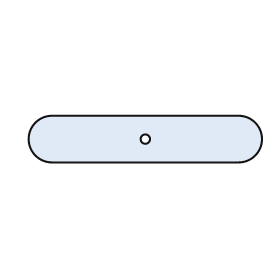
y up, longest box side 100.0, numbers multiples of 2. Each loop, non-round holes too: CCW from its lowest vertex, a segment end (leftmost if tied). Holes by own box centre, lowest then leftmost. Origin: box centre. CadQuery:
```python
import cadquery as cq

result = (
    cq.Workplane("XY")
    .moveTo(-40.0, -10.0)
    .lineTo(40.0, -10.0)
    .threePointArc((50.0, 0.0), (40.0, 10.0))
    .lineTo(-40.0, 10.0)
    .threePointArc((-50.0, 0.0), (-40.0, -10.0))
    .close()
    .moveTo(0.0, 0.0)
    .circle(2.0)
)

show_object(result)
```